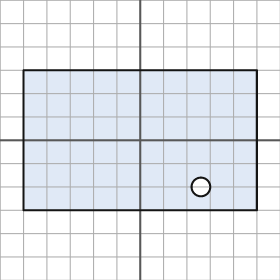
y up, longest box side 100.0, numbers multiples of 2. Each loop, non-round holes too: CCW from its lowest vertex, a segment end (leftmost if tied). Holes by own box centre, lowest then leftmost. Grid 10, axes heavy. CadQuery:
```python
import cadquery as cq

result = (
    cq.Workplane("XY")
    .moveTo(-50.0, -30.0)
    .lineTo(50.0, -30.0)
    .lineTo(50.0, 30.0)
    .lineTo(-50.0, 30.0)
    .close()
    .moveTo(26.0, -20.0)
    .circle(4.0)
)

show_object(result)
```